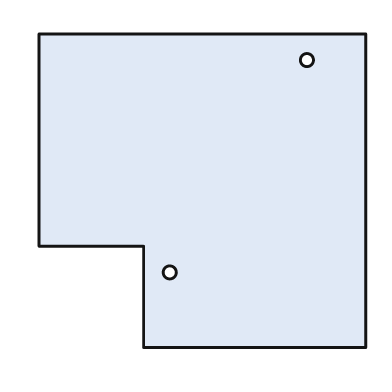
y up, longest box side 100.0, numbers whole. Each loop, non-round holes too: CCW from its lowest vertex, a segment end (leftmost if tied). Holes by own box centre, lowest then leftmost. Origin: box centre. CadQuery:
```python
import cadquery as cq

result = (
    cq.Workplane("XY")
    .moveTo(-18.0, -48.0)
    .lineTo(50.0, -48.0)
    .lineTo(50.0, 48.0)
    .lineTo(-50.0, 48.0)
    .lineTo(-50.0, -17.0)
    .lineTo(-18.0, -17.0)
    .close()
    .moveTo(-10.0, -25.0)
    .circle(2.0)
    .moveTo(32.0, 40.0)
    .circle(2.0)
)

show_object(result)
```